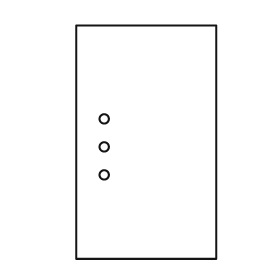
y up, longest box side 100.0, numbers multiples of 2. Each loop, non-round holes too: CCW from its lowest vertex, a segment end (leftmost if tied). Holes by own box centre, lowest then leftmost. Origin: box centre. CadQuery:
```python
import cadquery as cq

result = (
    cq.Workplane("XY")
    .moveTo(-30.0, -50.0)
    .lineTo(30.0, -50.0)
    .lineTo(30.0, 50.0)
    .lineTo(-30.0, 50.0)
    .close()
    .moveTo(-18.0, -14.0)
    .circle(2.0)
    .moveTo(-18.0, -2.0)
    .circle(2.0)
    .moveTo(-18.0, 10.0)
    .circle(2.0)
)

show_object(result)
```